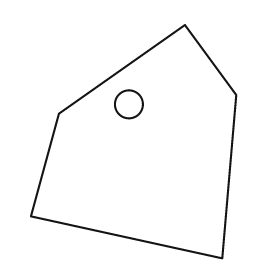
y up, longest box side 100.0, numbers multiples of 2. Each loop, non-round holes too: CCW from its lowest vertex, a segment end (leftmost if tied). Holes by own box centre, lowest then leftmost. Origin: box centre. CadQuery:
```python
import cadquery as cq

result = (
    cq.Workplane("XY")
    .moveTo(38.0, -50.0)
    .lineTo(44.0, 20.0)
    .lineTo(22.0, 50.0)
    .lineTo(-32.0, 12.0)
    .lineTo(-44.0, -32.0)
    .close()
    .moveTo(-2.0, 16.0)
    .circle(6.0)
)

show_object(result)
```